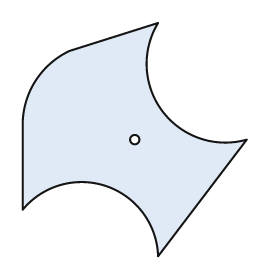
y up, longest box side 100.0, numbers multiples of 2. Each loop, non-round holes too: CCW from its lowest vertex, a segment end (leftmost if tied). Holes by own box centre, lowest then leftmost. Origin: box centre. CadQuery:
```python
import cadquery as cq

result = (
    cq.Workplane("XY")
    .moveTo(10.0, -50.0)
    .lineTo(48.0, 0.0)
    .threePointArc((12.0, 12.0), (10.0, 50.0))
    .lineTo(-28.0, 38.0)
    .threePointArc((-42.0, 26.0), (-48.0, 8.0))
    .lineTo(-48.0, -30.0)
    .threePointArc((-12.0, -20.0), (10.0, -50.0))
    .close()
    .moveTo(0.0, 0.0)
    .circle(2.0)
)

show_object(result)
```